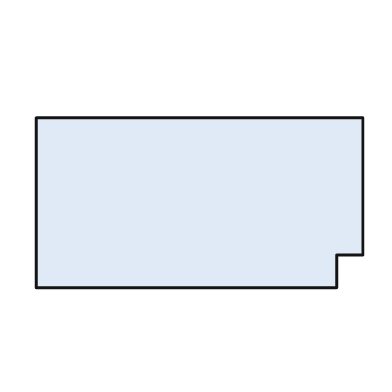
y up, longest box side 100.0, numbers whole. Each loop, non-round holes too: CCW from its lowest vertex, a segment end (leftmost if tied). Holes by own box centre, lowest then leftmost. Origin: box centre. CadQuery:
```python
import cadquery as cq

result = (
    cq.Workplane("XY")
    .moveTo(-50.0, -26.0)
    .lineTo(42.0, -26.0)
    .lineTo(42.0, -16.0)
    .lineTo(50.0, -16.0)
    .lineTo(50.0, 26.0)
    .lineTo(-50.0, 26.0)
    .close()
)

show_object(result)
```